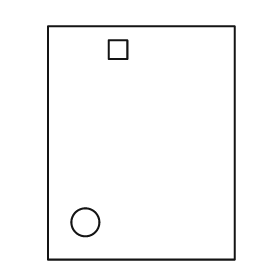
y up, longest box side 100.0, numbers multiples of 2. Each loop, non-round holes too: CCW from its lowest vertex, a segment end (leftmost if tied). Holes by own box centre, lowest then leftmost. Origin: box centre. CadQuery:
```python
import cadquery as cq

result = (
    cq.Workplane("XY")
    .moveTo(-40.0, -50.0)
    .lineTo(40.0, -50.0)
    .lineTo(40.0, 50.0)
    .lineTo(-40.0, 50.0)
    .close()
    .moveTo(-24.0, -34.0)
    .circle(6.0)
    .moveTo(-14.0, 36.0)
    .lineTo(-6.0, 36.0)
    .lineTo(-6.0, 44.0)
    .lineTo(-14.0, 44.0)
    .close()
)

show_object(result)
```